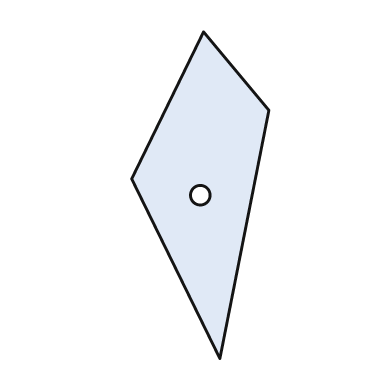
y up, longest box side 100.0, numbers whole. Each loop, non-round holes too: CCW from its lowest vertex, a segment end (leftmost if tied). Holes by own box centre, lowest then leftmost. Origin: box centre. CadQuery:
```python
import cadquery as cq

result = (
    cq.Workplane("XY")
    .moveTo(6.0, -50.0)
    .lineTo(21.0, 26.0)
    .lineTo(1.0, 50.0)
    .lineTo(-21.0, 5.0)
    .close()
    .moveTo(0.0, 0.0)
    .circle(3.0)
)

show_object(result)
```